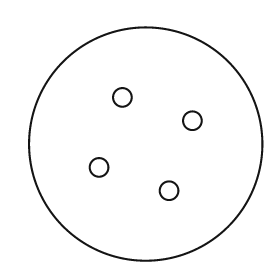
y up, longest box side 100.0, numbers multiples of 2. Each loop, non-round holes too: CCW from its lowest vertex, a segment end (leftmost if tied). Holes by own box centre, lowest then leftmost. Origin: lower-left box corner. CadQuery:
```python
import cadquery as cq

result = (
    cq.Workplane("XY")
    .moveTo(50.0, 50.0)
    .circle(50.0)
    .moveTo(60.0, 30.0)
    .circle(4.0)
    .moveTo(30.0, 40.0)
    .circle(4.0)
    .moveTo(70.0, 60.0)
    .circle(4.0)
    .moveTo(40.0, 70.0)
    .circle(4.0)
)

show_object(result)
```